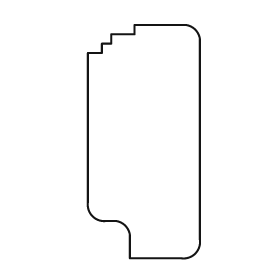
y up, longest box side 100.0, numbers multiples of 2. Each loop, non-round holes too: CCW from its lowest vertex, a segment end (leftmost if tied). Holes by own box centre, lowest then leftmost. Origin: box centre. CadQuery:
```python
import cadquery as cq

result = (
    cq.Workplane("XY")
    .moveTo(-6.0, -50.0)
    .lineTo(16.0, -50.0)
    .threePointArc((22.0, -48.0), (24.0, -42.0))
    .lineTo(24.0, 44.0)
    .threePointArc((22.0, 48.0), (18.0, 50.0))
    .lineTo(-4.0, 50.0)
    .lineTo(-4.0, 46.0)
    .lineTo(-14.0, 46.0)
    .lineTo(-14.0, 42.0)
    .lineTo(-18.0, 42.0)
    .lineTo(-18.0, 38.0)
    .lineTo(-24.0, 38.0)
    .lineTo(-24.0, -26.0)
    .threePointArc((-22.0, -32.0), (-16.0, -34.0))
    .lineTo(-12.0, -34.0)
    .threePointArc((-8.0, -36.0), (-6.0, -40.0))
    .close()
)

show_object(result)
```